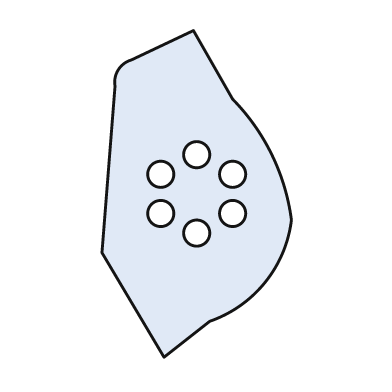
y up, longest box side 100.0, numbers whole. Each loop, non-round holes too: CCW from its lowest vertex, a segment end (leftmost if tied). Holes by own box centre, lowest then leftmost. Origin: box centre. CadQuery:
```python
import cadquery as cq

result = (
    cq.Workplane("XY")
    .moveTo(-10.0, -50.0)
    .lineTo(4.0, -39.0)
    .threePointArc((21.0, -27.0), (29.0, -8.0))
    .threePointArc((23.0, 12.0), (11.0, 29.0))
    .lineTo(-1.0, 50.0)
    .lineTo(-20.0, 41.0)
    .threePointArc((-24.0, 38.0), (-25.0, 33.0))
    .lineTo(-29.0, -18.0)
    .close()
    .moveTo(0.0, -12.0)
    .circle(4.0)
    .moveTo(-11.0, -6.0)
    .circle(4.0)
    .moveTo(11.0, -6.0)
    .circle(4.0)
    .moveTo(-11.0, 6.0)
    .circle(4.0)
    .moveTo(11.0, 6.0)
    .circle(4.0)
    .moveTo(0.0, 12.0)
    .circle(4.0)
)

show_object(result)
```